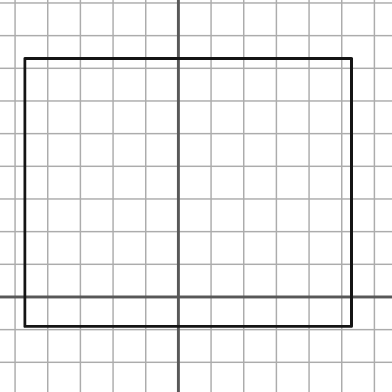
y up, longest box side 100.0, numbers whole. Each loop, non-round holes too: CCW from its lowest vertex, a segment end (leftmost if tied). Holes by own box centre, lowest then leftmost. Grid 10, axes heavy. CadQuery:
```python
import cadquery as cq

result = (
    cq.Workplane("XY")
    .moveTo(-47.0, -9.0)
    .lineTo(53.0, -9.0)
    .lineTo(53.0, 73.0)
    .lineTo(-47.0, 73.0)
    .close()
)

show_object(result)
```